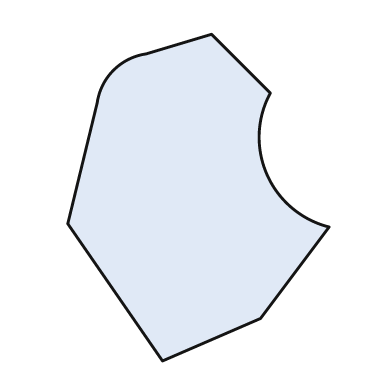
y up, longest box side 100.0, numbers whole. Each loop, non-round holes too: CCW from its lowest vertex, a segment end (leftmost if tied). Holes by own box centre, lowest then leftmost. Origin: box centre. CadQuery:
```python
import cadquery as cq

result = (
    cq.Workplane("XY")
    .moveTo(-11.0, -50.0)
    .lineTo(19.0, -37.0)
    .lineTo(40.0, -9.0)
    .threePointArc((21.0, 7.0), (22.0, 32.0))
    .lineTo(4.0, 50.0)
    .lineTo(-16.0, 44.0)
    .threePointArc((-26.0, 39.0), (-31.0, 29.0))
    .lineTo(-40.0, -8.0)
    .close()
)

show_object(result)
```